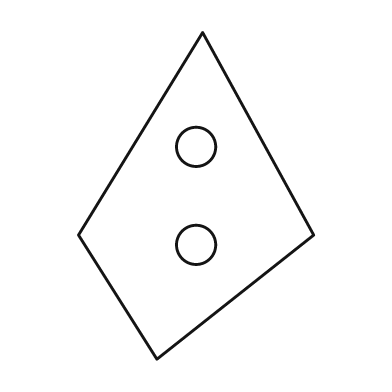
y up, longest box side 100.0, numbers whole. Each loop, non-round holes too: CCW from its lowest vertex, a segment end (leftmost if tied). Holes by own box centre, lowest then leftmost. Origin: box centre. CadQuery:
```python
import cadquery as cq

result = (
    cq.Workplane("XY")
    .moveTo(-12.0, -50.0)
    .lineTo(36.0, -12.0)
    .lineTo(2.0, 50.0)
    .lineTo(-36.0, -12.0)
    .close()
    .moveTo(0.0, -15.0)
    .circle(6.0)
    .moveTo(0.0, 15.0)
    .circle(6.0)
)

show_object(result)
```